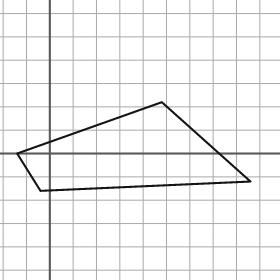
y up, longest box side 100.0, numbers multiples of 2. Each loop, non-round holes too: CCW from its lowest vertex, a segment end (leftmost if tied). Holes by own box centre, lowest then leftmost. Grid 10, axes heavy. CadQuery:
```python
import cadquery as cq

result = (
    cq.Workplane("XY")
    .moveTo(-4.0, -16.0)
    .lineTo(86.0, -12.0)
    .lineTo(48.0, 22.0)
    .lineTo(-14.0, 0.0)
    .close()
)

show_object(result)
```